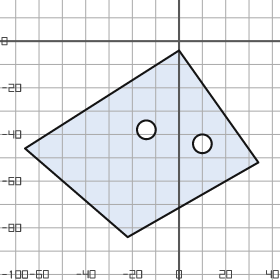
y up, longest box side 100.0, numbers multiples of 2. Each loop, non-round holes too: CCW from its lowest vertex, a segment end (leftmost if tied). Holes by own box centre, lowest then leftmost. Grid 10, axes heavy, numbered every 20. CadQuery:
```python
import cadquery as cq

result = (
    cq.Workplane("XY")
    .moveTo(-22.0, -84.0)
    .lineTo(34.0, -52.0)
    .lineTo(0.0, -4.0)
    .lineTo(-66.0, -46.0)
    .close()
    .moveTo(10.0, -44.0)
    .circle(4.0)
    .moveTo(-14.0, -38.0)
    .circle(4.0)
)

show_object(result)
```